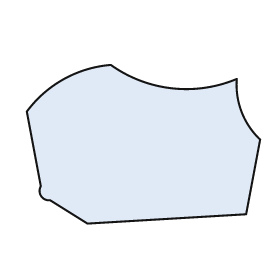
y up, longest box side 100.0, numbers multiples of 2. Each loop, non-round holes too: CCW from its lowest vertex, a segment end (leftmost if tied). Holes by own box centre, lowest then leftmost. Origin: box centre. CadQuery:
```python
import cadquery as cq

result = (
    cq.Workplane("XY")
    .moveTo(-24.0, -34.0)
    .lineTo(44.0, -30.0)
    .lineTo(50.0, 2.0)
    .threePointArc((42.0, 14.0), (40.0, 28.0))
    .threePointArc((12.0, 24.0), (-14.0, 34.0))
    .threePointArc((-34.0, 28.0), (-50.0, 14.0))
    .lineTo(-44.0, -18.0)
    .threePointArc((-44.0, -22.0), (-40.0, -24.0))
    .close()
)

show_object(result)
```